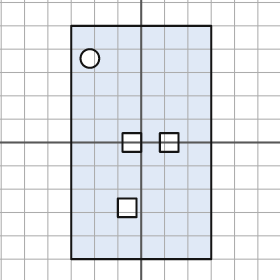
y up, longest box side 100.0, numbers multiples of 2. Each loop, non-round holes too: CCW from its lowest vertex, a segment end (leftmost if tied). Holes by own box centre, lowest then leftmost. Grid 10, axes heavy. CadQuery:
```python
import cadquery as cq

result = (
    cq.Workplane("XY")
    .moveTo(-30.0, -50.0)
    .lineTo(30.0, -50.0)
    .lineTo(30.0, 50.0)
    .lineTo(-30.0, 50.0)
    .close()
    .moveTo(-10.0, -32.0)
    .lineTo(-2.0, -32.0)
    .lineTo(-2.0, -24.0)
    .lineTo(-10.0, -24.0)
    .close()
    .moveTo(-8.0, -4.0)
    .lineTo(0.0, -4.0)
    .lineTo(0.0, 4.0)
    .lineTo(-8.0, 4.0)
    .close()
    .moveTo(8.0, -4.0)
    .lineTo(16.0, -4.0)
    .lineTo(16.0, 4.0)
    .lineTo(8.0, 4.0)
    .close()
    .moveTo(-22.0, 36.0)
    .circle(4.0)
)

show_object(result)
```